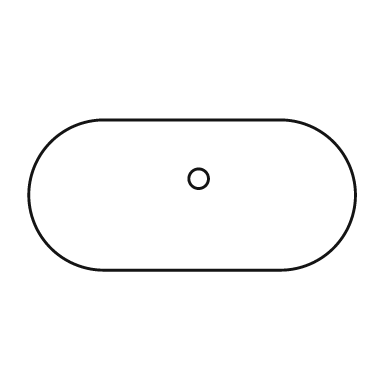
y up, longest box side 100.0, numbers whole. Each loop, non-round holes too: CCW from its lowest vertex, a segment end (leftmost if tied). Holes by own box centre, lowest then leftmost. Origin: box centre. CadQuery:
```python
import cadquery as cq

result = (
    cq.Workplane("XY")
    .moveTo(-27.0, -23.0)
    .lineTo(27.0, -23.0)
    .threePointArc((50.0, 0.0), (27.0, 23.0))
    .lineTo(-27.0, 23.0)
    .threePointArc((-50.0, 0.0), (-27.0, -23.0))
    .close()
    .moveTo(2.0, 5.0)
    .circle(3.0)
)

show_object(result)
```